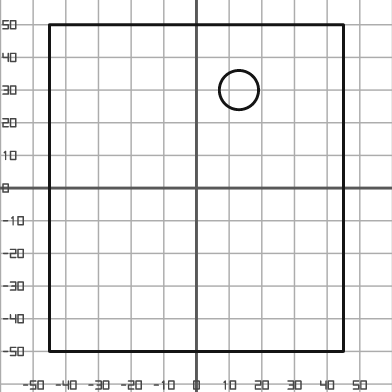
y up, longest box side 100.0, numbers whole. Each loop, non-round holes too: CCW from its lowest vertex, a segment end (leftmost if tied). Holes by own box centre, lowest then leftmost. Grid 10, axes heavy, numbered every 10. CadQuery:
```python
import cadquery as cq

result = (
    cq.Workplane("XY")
    .moveTo(-45.0, -50.0)
    .lineTo(45.0, -50.0)
    .lineTo(45.0, 50.0)
    .lineTo(-45.0, 50.0)
    .close()
    .moveTo(13.0, 30.0)
    .circle(6.0)
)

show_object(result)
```